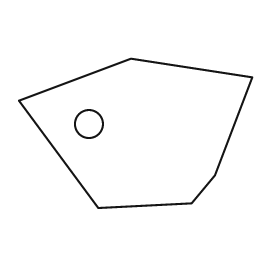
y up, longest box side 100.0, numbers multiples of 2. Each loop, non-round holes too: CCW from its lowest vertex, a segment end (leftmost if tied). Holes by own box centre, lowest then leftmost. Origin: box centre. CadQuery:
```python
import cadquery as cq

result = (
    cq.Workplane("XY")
    .moveTo(-16.0, -32.0)
    .lineTo(24.0, -30.0)
    .lineTo(34.0, -18.0)
    .lineTo(50.0, 24.0)
    .lineTo(-2.0, 32.0)
    .lineTo(-50.0, 14.0)
    .close()
    .moveTo(-20.0, 4.0)
    .circle(6.0)
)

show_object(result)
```